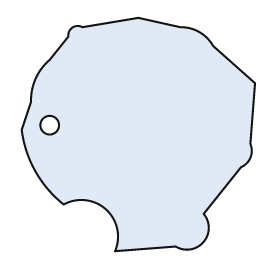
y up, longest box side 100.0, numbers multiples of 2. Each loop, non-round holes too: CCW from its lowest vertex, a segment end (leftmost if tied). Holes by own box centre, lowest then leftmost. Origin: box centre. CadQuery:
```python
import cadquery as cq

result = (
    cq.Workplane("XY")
    .moveTo(-10.0, -50.0)
    .lineTo(16.0, -48.0)
    .threePointArc((28.0, -46.0), (28.0, -34.0))
    .lineTo(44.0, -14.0)
    .threePointArc((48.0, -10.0), (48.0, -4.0))
    .lineTo(50.0, 22.0)
    .lineTo(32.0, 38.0)
    .threePointArc((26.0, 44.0), (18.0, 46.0))
    .lineTo(0.0, 50.0)
    .lineTo(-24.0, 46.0)
    .threePointArc((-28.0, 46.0), (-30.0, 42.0))
    .lineTo(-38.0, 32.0)
    .threePointArc((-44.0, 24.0), (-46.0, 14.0))
    .lineTo(-50.0, 2.0)
    .threePointArc((-44.0, -16.0), (-32.0, -30.0))
    .threePointArc((-14.0, -32.0), (-10.0, -50.0))
    .close()
    .moveTo(-38.0, 4.0)
    .circle(4.0)
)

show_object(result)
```